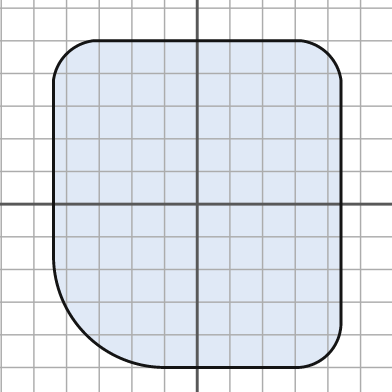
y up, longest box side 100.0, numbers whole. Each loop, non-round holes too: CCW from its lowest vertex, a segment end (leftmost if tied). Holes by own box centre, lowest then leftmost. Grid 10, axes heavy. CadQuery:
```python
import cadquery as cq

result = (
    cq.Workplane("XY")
    .moveTo(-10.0, -50.0)
    .lineTo(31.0, -50.0)
    .threePointArc((40.0, -46.0), (44.0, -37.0))
    .lineTo(44.0, 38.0)
    .threePointArc((40.0, 46.0), (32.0, 50.0))
    .lineTo(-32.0, 50.0)
    .threePointArc((-40.0, 46.0), (-44.0, 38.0))
    .lineTo(-44.0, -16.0)
    .threePointArc((-34.0, -40.0), (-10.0, -50.0))
    .close()
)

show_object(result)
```